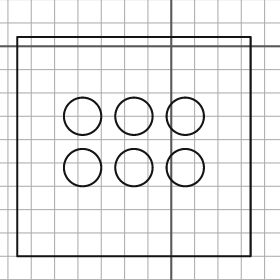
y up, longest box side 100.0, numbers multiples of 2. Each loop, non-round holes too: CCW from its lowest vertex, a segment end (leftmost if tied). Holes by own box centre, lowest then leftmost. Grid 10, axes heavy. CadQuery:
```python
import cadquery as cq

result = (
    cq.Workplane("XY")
    .moveTo(-66.0, -90.0)
    .lineTo(34.0, -90.0)
    .lineTo(34.0, 4.0)
    .lineTo(-66.0, 4.0)
    .close()
    .moveTo(-38.0, -52.0)
    .circle(8.0)
    .moveTo(-16.0, -52.0)
    .circle(8.0)
    .moveTo(6.0, -52.0)
    .circle(8.0)
    .moveTo(-38.0, -30.0)
    .circle(8.0)
    .moveTo(-16.0, -30.0)
    .circle(8.0)
    .moveTo(6.0, -30.0)
    .circle(8.0)
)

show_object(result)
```